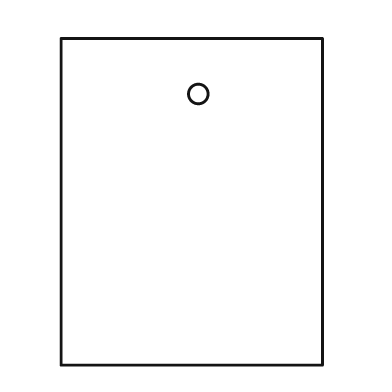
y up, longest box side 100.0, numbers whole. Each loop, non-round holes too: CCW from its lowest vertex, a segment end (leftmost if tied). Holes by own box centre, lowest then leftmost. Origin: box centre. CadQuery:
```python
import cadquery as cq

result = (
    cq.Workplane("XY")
    .moveTo(-40.0, -50.0)
    .lineTo(40.0, -50.0)
    .lineTo(40.0, 50.0)
    .lineTo(-40.0, 50.0)
    .close()
    .moveTo(2.0, 33.0)
    .circle(3.0)
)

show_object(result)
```